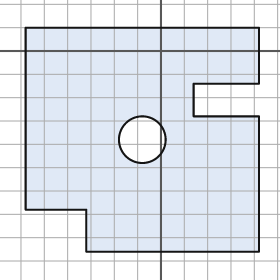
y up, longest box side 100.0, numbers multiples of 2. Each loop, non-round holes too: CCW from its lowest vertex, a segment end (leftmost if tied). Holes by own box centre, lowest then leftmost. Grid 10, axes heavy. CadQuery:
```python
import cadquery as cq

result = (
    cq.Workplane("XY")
    .moveTo(-32.0, -86.0)
    .lineTo(42.0, -86.0)
    .lineTo(42.0, -28.0)
    .lineTo(14.0, -28.0)
    .lineTo(14.0, -14.0)
    .lineTo(42.0, -14.0)
    .lineTo(42.0, 10.0)
    .lineTo(-58.0, 10.0)
    .lineTo(-58.0, -68.0)
    .lineTo(-32.0, -68.0)
    .close()
    .moveTo(-8.0, -38.0)
    .circle(10.0)
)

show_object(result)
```